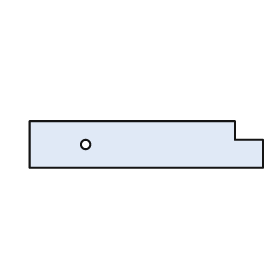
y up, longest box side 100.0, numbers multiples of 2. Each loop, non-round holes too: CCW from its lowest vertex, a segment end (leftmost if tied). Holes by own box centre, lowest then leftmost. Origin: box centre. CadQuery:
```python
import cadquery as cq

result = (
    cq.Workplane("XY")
    .moveTo(-50.0, -10.0)
    .lineTo(50.0, -10.0)
    .lineTo(50.0, 2.0)
    .lineTo(38.0, 2.0)
    .lineTo(38.0, 10.0)
    .lineTo(-50.0, 10.0)
    .close()
    .moveTo(-26.0, 0.0)
    .circle(2.0)
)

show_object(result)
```